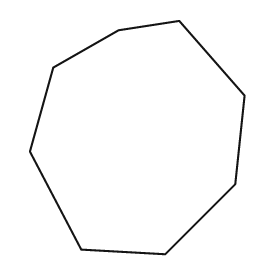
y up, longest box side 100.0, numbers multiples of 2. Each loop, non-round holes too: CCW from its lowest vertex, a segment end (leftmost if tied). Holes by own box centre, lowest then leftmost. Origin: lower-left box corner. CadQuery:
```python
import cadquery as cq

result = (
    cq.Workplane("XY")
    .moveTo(58.0, 0.0)
    .lineTo(88.0, 30.0)
    .lineTo(92.0, 68.0)
    .lineTo(64.0, 100.0)
    .lineTo(38.0, 96.0)
    .lineTo(10.0, 80.0)
    .lineTo(0.0, 44.0)
    .lineTo(22.0, 2.0)
    .close()
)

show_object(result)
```